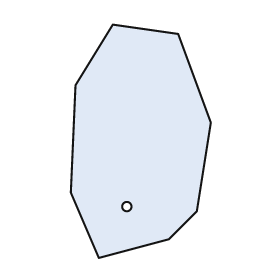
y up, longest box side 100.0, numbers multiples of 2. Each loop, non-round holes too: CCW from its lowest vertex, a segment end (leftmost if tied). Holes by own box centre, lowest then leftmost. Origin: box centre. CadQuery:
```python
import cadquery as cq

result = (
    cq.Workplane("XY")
    .moveTo(-18.0, -50.0)
    .lineTo(12.0, -42.0)
    .lineTo(24.0, -30.0)
    .lineTo(30.0, 8.0)
    .lineTo(16.0, 46.0)
    .lineTo(-12.0, 50.0)
    .lineTo(-28.0, 24.0)
    .lineTo(-30.0, -22.0)
    .close()
    .moveTo(-6.0, -28.0)
    .circle(2.0)
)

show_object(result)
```